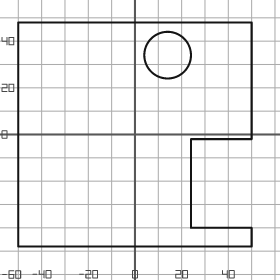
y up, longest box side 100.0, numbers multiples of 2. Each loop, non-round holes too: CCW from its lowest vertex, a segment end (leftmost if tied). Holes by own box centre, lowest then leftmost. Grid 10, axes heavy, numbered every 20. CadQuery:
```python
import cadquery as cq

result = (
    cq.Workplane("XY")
    .moveTo(-50.0, -48.0)
    .lineTo(50.0, -48.0)
    .lineTo(50.0, -40.0)
    .lineTo(24.0, -40.0)
    .lineTo(24.0, -2.0)
    .lineTo(50.0, -2.0)
    .lineTo(50.0, 48.0)
    .lineTo(-50.0, 48.0)
    .close()
    .moveTo(14.0, 34.0)
    .circle(10.0)
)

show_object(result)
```